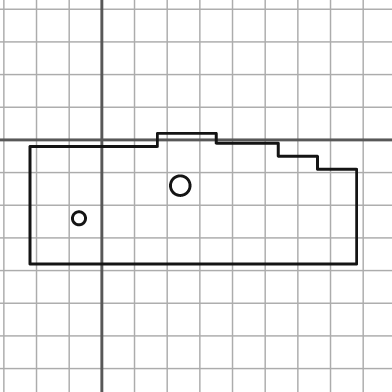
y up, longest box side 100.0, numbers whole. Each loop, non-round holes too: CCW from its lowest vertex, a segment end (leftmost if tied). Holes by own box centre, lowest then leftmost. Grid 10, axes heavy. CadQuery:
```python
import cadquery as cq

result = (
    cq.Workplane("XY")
    .moveTo(-22.0, -38.0)
    .lineTo(78.0, -38.0)
    .lineTo(78.0, -9.0)
    .lineTo(66.0, -9.0)
    .lineTo(66.0, -5.0)
    .lineTo(54.0, -5.0)
    .lineTo(54.0, -1.0)
    .lineTo(35.0, -1.0)
    .lineTo(35.0, 2.0)
    .lineTo(17.0, 2.0)
    .lineTo(17.0, -2.0)
    .lineTo(-22.0, -2.0)
    .close()
    .moveTo(-7.0, -24.0)
    .circle(2.0)
    .moveTo(24.0, -14.0)
    .circle(3.0)
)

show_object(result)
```